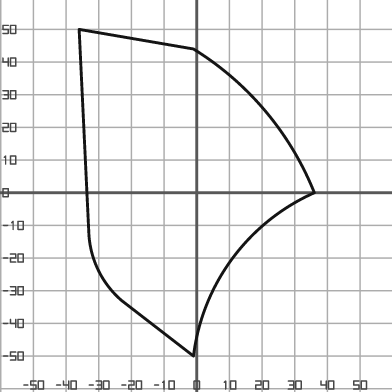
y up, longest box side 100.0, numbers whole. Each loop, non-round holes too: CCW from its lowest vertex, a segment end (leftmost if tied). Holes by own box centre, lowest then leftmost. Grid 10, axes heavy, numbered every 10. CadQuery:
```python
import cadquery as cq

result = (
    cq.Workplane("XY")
    .moveTo(-1.0, -50.0)
    .threePointArc((11.0, -20.0), (36.0, 0.0))
    .threePointArc((21.0, 25.0), (-1.0, 44.0))
    .lineTo(-36.0, 50.0)
    .lineTo(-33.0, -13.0)
    .threePointArc((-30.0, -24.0), (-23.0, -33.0))
    .close()
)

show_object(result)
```